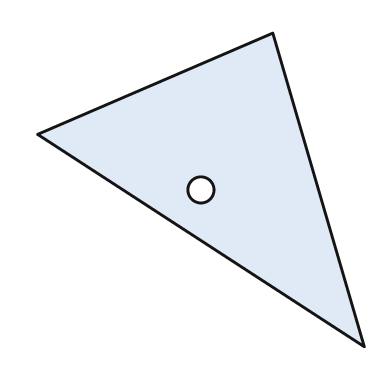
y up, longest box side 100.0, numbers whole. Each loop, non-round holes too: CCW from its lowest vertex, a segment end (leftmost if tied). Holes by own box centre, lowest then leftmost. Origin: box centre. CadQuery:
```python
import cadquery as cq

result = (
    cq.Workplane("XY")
    .moveTo(50.0, -48.0)
    .lineTo(22.0, 48.0)
    .lineTo(-50.0, 17.0)
    .close()
    .moveTo(0.0, 0.0)
    .circle(4.0)
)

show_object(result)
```